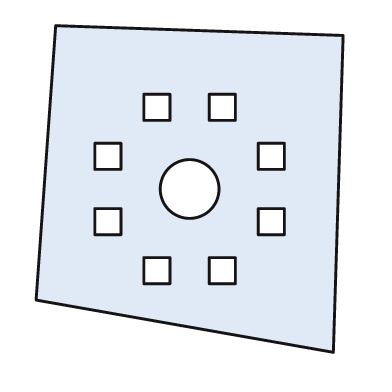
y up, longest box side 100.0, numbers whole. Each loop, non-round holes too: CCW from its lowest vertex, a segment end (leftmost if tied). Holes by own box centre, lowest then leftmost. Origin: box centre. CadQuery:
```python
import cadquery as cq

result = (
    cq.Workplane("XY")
    .moveTo(44.0, -50.0)
    .lineTo(47.0, 47.0)
    .lineTo(-41.0, 50.0)
    .lineTo(-47.0, -34.0)
    .close()
    .moveTo(-14.0, -29.0)
    .lineTo(-6.0, -29.0)
    .lineTo(-6.0, -21.0)
    .lineTo(-14.0, -21.0)
    .close()
    .moveTo(6.0, -29.0)
    .lineTo(14.0, -29.0)
    .lineTo(14.0, -21.0)
    .lineTo(6.0, -21.0)
    .close()
    .moveTo(-29.0, -14.0)
    .lineTo(-21.0, -14.0)
    .lineTo(-21.0, -6.0)
    .lineTo(-29.0, -6.0)
    .close()
    .moveTo(21.0, -14.0)
    .lineTo(29.0, -14.0)
    .lineTo(29.0, -6.0)
    .lineTo(21.0, -6.0)
    .close()
    .moveTo(0.0, 0.0)
    .circle(9.0)
    .moveTo(-29.0, 6.0)
    .lineTo(-21.0, 6.0)
    .lineTo(-21.0, 14.0)
    .lineTo(-29.0, 14.0)
    .close()
    .moveTo(21.0, 6.0)
    .lineTo(29.0, 6.0)
    .lineTo(29.0, 14.0)
    .lineTo(21.0, 14.0)
    .close()
    .moveTo(-14.0, 21.0)
    .lineTo(-6.0, 21.0)
    .lineTo(-6.0, 29.0)
    .lineTo(-14.0, 29.0)
    .close()
    .moveTo(6.0, 21.0)
    .lineTo(14.0, 21.0)
    .lineTo(14.0, 29.0)
    .lineTo(6.0, 29.0)
    .close()
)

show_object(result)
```